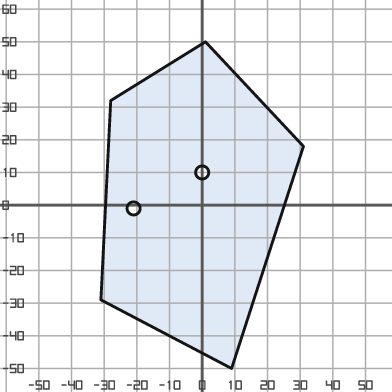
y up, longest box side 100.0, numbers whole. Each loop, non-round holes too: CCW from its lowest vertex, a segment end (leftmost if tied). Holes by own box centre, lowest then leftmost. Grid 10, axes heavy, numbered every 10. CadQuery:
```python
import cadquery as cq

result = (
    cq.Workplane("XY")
    .moveTo(9.0, -50.0)
    .lineTo(31.0, 18.0)
    .lineTo(1.0, 50.0)
    .lineTo(-28.0, 32.0)
    .lineTo(-31.0, -29.0)
    .close()
    .moveTo(-21.0, -1.0)
    .circle(2.0)
    .moveTo(0.0, 10.0)
    .circle(2.0)
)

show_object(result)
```